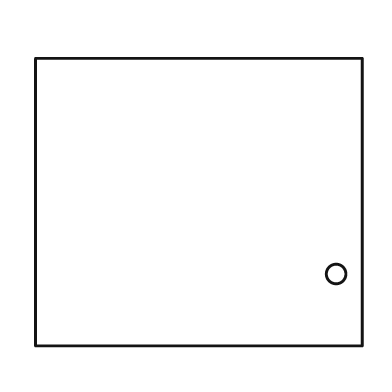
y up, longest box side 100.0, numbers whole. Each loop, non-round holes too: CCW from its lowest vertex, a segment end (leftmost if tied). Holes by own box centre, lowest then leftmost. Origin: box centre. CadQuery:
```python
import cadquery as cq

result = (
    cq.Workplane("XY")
    .moveTo(-50.0, -44.0)
    .lineTo(50.0, -44.0)
    .lineTo(50.0, 44.0)
    .lineTo(-50.0, 44.0)
    .close()
    .moveTo(42.0, -22.0)
    .circle(3.0)
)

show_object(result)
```